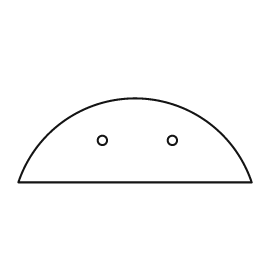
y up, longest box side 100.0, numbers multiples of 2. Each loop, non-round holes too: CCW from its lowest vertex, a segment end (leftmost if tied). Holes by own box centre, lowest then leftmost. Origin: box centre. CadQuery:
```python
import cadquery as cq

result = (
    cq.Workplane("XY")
    .moveTo(-50.0, -18.0)
    .lineTo(50.0, -18.0)
    .threePointArc((0.0, 18.0), (-50.0, -18.0))
    .close()
    .moveTo(-14.0, 0.0)
    .circle(2.0)
    .moveTo(16.0, 0.0)
    .circle(2.0)
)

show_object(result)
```